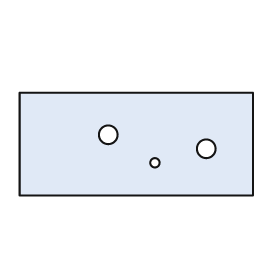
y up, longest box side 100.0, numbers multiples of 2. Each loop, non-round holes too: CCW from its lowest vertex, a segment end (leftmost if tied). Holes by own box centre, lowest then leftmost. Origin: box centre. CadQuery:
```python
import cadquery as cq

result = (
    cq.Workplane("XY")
    .moveTo(-50.0, -22.0)
    .lineTo(50.0, -22.0)
    .lineTo(50.0, 22.0)
    .lineTo(-50.0, 22.0)
    .close()
    .moveTo(8.0, -8.0)
    .circle(2.0)
    .moveTo(30.0, -2.0)
    .circle(4.0)
    .moveTo(-12.0, 4.0)
    .circle(4.0)
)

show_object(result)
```